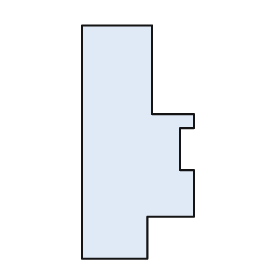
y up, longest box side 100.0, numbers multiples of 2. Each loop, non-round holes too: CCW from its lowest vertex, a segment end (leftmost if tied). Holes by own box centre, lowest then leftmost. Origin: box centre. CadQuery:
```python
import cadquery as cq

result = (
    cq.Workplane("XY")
    .moveTo(-24.0, -50.0)
    .lineTo(4.0, -50.0)
    .lineTo(4.0, -32.0)
    .lineTo(24.0, -32.0)
    .lineTo(24.0, -12.0)
    .lineTo(18.0, -12.0)
    .lineTo(18.0, 6.0)
    .lineTo(24.0, 6.0)
    .lineTo(24.0, 12.0)
    .lineTo(6.0, 12.0)
    .lineTo(6.0, 50.0)
    .lineTo(-24.0, 50.0)
    .close()
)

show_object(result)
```